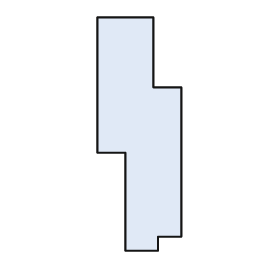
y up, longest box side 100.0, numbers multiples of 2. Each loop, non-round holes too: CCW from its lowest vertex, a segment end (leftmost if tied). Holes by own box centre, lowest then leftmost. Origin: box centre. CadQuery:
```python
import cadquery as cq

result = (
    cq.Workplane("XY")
    .moveTo(-6.0, -50.0)
    .lineTo(8.0, -50.0)
    .lineTo(8.0, -44.0)
    .lineTo(18.0, -44.0)
    .lineTo(18.0, 20.0)
    .lineTo(6.0, 20.0)
    .lineTo(6.0, 50.0)
    .lineTo(-18.0, 50.0)
    .lineTo(-18.0, -8.0)
    .lineTo(-6.0, -8.0)
    .close()
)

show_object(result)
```